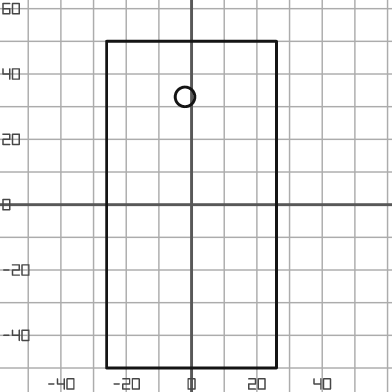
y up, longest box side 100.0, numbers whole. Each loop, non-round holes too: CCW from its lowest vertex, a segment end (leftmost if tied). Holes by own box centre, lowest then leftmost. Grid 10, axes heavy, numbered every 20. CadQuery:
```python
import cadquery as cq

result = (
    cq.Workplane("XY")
    .moveTo(-26.0, -50.0)
    .lineTo(26.0, -50.0)
    .lineTo(26.0, 50.0)
    .lineTo(-26.0, 50.0)
    .close()
    .moveTo(-2.0, 33.0)
    .circle(3.0)
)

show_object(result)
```